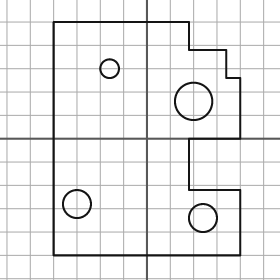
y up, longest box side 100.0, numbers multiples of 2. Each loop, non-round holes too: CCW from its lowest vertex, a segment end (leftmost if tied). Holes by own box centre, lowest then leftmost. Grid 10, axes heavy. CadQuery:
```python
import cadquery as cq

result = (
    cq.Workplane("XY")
    .moveTo(-40.0, -50.0)
    .lineTo(40.0, -50.0)
    .lineTo(40.0, -22.0)
    .lineTo(18.0, -22.0)
    .lineTo(18.0, 0.0)
    .lineTo(40.0, 0.0)
    .lineTo(40.0, 26.0)
    .lineTo(34.0, 26.0)
    .lineTo(34.0, 38.0)
    .lineTo(18.0, 38.0)
    .lineTo(18.0, 50.0)
    .lineTo(-40.0, 50.0)
    .close()
    .moveTo(24.0, -34.0)
    .circle(6.0)
    .moveTo(-30.0, -28.0)
    .circle(6.0)
    .moveTo(20.0, 16.0)
    .circle(8.0)
    .moveTo(-16.0, 30.0)
    .circle(4.0)
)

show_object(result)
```